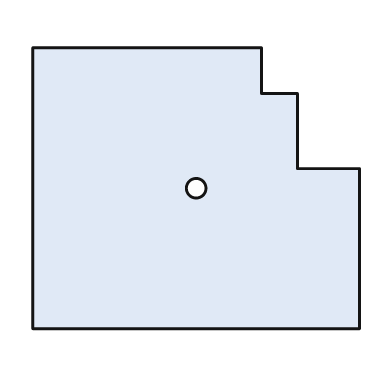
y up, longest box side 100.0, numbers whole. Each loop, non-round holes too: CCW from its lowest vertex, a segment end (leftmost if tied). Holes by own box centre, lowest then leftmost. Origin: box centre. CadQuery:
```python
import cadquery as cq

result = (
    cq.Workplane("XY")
    .moveTo(-50.0, -43.0)
    .lineTo(50.0, -43.0)
    .lineTo(50.0, 6.0)
    .lineTo(31.0, 6.0)
    .lineTo(31.0, 29.0)
    .lineTo(20.0, 29.0)
    .lineTo(20.0, 43.0)
    .lineTo(-50.0, 43.0)
    .close()
    .moveTo(0.0, 0.0)
    .circle(3.0)
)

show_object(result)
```